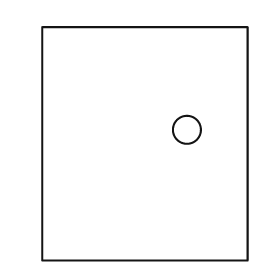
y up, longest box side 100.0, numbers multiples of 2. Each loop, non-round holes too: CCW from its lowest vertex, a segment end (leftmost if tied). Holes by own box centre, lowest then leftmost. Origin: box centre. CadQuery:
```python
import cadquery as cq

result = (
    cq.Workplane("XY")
    .moveTo(-44.0, -50.0)
    .lineTo(44.0, -50.0)
    .lineTo(44.0, 50.0)
    .lineTo(-44.0, 50.0)
    .close()
    .moveTo(18.0, 6.0)
    .circle(6.0)
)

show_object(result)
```